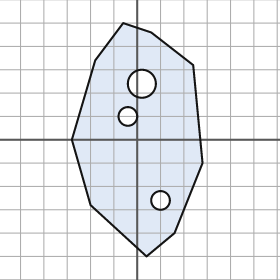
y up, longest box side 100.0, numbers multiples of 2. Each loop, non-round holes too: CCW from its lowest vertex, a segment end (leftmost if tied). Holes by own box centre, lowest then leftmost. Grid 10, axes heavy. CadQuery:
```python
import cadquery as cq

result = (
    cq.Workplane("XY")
    .moveTo(4.0, -50.0)
    .lineTo(16.0, -40.0)
    .lineTo(28.0, -10.0)
    .lineTo(24.0, 32.0)
    .lineTo(6.0, 46.0)
    .lineTo(-6.0, 50.0)
    .lineTo(-18.0, 34.0)
    .lineTo(-28.0, 0.0)
    .lineTo(-20.0, -28.0)
    .close()
    .moveTo(10.0, -26.0)
    .circle(4.0)
    .moveTo(-4.0, 10.0)
    .circle(4.0)
    .moveTo(2.0, 24.0)
    .circle(6.0)
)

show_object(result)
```